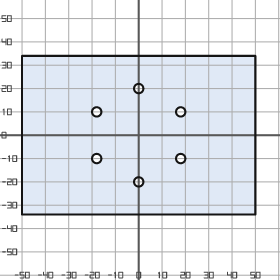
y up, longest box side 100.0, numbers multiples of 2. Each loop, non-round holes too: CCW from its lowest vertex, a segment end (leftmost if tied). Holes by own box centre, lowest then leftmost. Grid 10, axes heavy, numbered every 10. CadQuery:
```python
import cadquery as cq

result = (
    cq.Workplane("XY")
    .moveTo(-50.0, -34.0)
    .lineTo(50.0, -34.0)
    .lineTo(50.0, 34.0)
    .lineTo(-50.0, 34.0)
    .close()
    .moveTo(0.0, -20.0)
    .circle(2.0)
    .moveTo(-18.0, -10.0)
    .circle(2.0)
    .moveTo(18.0, -10.0)
    .circle(2.0)
    .moveTo(-18.0, 10.0)
    .circle(2.0)
    .moveTo(18.0, 10.0)
    .circle(2.0)
    .moveTo(0.0, 20.0)
    .circle(2.0)
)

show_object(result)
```